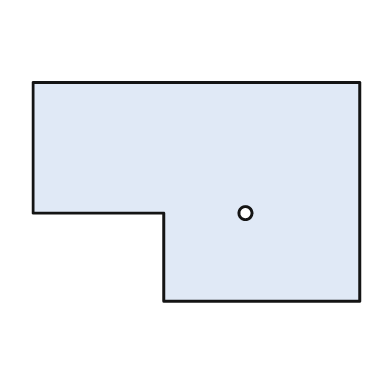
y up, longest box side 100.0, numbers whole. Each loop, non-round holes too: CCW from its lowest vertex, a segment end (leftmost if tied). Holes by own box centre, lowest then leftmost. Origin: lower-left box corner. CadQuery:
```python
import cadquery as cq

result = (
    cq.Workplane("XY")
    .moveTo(40.0, 0.0)
    .lineTo(100.0, 0.0)
    .lineTo(100.0, 67.0)
    .lineTo(0.0, 67.0)
    .lineTo(0.0, 27.0)
    .lineTo(40.0, 27.0)
    .close()
    .moveTo(65.0, 27.0)
    .circle(2.0)
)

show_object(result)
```